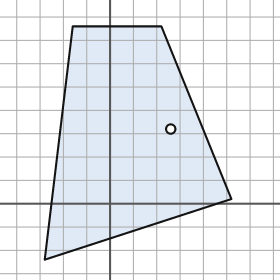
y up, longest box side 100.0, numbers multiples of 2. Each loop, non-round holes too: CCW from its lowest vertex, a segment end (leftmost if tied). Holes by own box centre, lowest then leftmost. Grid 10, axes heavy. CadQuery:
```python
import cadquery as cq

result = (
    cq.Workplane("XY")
    .moveTo(-28.0, -24.0)
    .lineTo(52.0, 2.0)
    .lineTo(22.0, 76.0)
    .lineTo(-16.0, 76.0)
    .close()
    .moveTo(26.0, 32.0)
    .circle(2.0)
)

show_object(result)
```